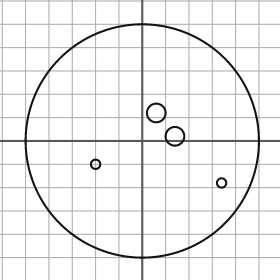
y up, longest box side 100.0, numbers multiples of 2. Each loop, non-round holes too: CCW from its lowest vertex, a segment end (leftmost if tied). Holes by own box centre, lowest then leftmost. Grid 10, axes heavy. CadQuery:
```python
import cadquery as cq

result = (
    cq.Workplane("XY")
    .moveTo(0.0, 0.0)
    .circle(50.0)
    .moveTo(34.0, -18.0)
    .circle(2.0)
    .moveTo(-20.0, -10.0)
    .circle(2.0)
    .moveTo(14.0, 2.0)
    .circle(4.0)
    .moveTo(6.0, 12.0)
    .circle(4.0)
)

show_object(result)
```